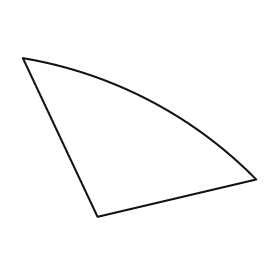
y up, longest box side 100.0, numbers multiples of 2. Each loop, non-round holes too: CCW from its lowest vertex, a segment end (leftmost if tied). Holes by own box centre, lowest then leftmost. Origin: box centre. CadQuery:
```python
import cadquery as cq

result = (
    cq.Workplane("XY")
    .moveTo(-18.0, -34.0)
    .lineTo(50.0, -18.0)
    .threePointArc((4.0, 16.0), (-50.0, 34.0))
    .close()
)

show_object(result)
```